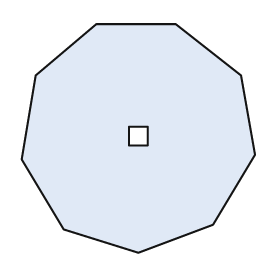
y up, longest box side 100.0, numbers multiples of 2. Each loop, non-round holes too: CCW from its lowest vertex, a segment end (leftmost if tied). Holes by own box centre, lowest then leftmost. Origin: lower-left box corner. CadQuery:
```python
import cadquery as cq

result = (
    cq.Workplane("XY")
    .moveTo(50.0, 0.0)
    .lineTo(82.0, 12.0)
    .lineTo(100.0, 42.0)
    .lineTo(94.0, 76.0)
    .lineTo(66.0, 98.0)
    .lineTo(32.0, 98.0)
    .lineTo(6.0, 76.0)
    .lineTo(0.0, 40.0)
    .lineTo(18.0, 10.0)
    .close()
    .moveTo(46.0, 46.0)
    .lineTo(54.0, 46.0)
    .lineTo(54.0, 54.0)
    .lineTo(46.0, 54.0)
    .close()
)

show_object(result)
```